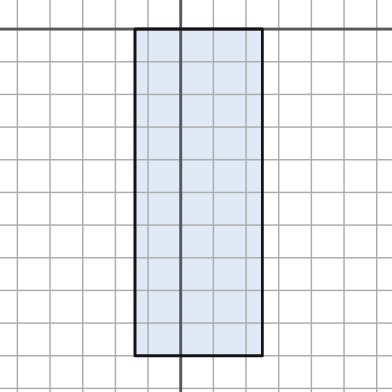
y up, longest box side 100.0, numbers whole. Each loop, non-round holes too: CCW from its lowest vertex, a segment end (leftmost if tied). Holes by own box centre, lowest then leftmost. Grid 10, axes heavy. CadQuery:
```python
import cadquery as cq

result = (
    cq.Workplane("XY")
    .moveTo(-14.0, -100.0)
    .lineTo(25.0, -100.0)
    .lineTo(25.0, 0.0)
    .lineTo(-14.0, 0.0)
    .close()
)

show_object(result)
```